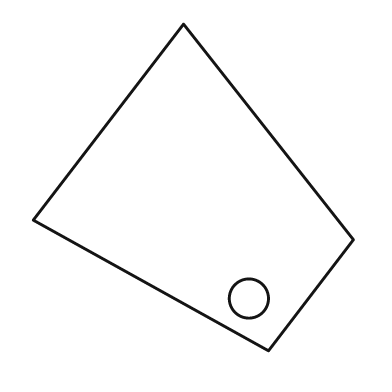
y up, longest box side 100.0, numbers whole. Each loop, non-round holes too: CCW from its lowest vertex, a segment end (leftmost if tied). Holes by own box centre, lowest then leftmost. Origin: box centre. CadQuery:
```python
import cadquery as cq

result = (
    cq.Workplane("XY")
    .moveTo(23.0, -50.0)
    .lineTo(49.0, -16.0)
    .lineTo(-3.0, 50.0)
    .lineTo(-49.0, -10.0)
    .close()
    .moveTo(17.0, -34.0)
    .circle(6.0)
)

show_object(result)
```